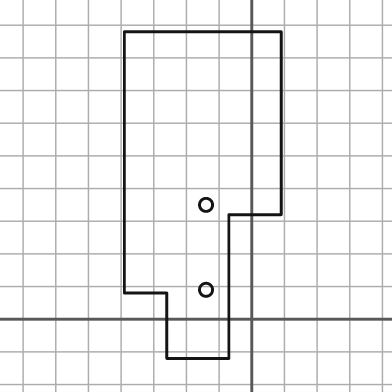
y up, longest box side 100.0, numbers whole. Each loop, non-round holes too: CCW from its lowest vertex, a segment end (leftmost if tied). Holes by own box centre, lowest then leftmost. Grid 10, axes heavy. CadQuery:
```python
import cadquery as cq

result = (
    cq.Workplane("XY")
    .moveTo(-26.0, -12.0)
    .lineTo(-7.0, -12.0)
    .lineTo(-7.0, 32.0)
    .lineTo(9.0, 32.0)
    .lineTo(9.0, 88.0)
    .lineTo(-39.0, 88.0)
    .lineTo(-39.0, 8.0)
    .lineTo(-26.0, 8.0)
    .close()
    .moveTo(-14.0, 9.0)
    .circle(2.0)
    .moveTo(-14.0, 35.0)
    .circle(2.0)
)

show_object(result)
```